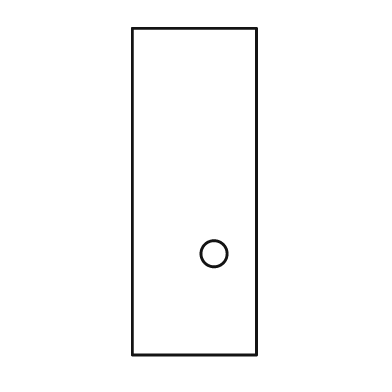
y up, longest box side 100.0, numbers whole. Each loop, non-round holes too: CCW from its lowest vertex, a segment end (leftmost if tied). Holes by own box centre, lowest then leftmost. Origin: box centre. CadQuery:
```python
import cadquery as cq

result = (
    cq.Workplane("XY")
    .moveTo(-19.0, -50.0)
    .lineTo(19.0, -50.0)
    .lineTo(19.0, 50.0)
    .lineTo(-19.0, 50.0)
    .close()
    .moveTo(6.0, -19.0)
    .circle(4.0)
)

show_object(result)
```